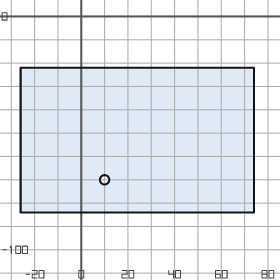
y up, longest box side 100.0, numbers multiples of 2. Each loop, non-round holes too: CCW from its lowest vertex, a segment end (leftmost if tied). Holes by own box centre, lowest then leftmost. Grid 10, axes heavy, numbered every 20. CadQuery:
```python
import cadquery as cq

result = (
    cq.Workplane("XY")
    .moveTo(-26.0, -84.0)
    .lineTo(74.0, -84.0)
    .lineTo(74.0, -22.0)
    .lineTo(-26.0, -22.0)
    .close()
    .moveTo(10.0, -70.0)
    .circle(2.0)
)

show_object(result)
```